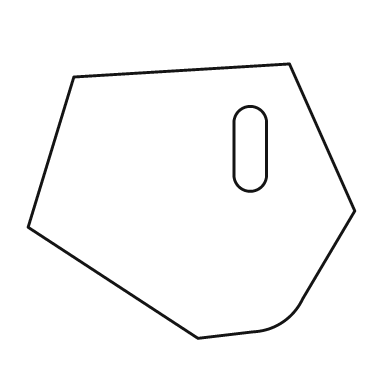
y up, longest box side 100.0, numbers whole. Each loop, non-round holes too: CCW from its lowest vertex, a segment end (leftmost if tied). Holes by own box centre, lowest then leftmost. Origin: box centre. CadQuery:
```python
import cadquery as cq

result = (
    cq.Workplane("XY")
    .moveTo(2.0, -42.0)
    .lineTo(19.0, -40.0)
    .threePointArc((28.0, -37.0), (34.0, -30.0))
    .lineTo(50.0, -3.0)
    .lineTo(30.0, 42.0)
    .lineTo(-36.0, 38.0)
    .lineTo(-50.0, -8.0)
    .close()
    .moveTo(13.0, 8.0)
    .threePointArc((18.0, 3.0), (23.0, 8.0))
    .lineTo(23.0, 24.0)
    .threePointArc((18.0, 29.0), (13.0, 24.0))
    .close()
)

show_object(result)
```